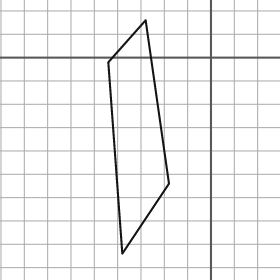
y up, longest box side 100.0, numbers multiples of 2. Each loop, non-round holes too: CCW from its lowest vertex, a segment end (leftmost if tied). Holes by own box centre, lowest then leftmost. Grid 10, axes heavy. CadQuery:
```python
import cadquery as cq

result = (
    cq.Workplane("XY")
    .moveTo(-38.0, -84.0)
    .lineTo(-18.0, -54.0)
    .lineTo(-28.0, 16.0)
    .lineTo(-44.0, -2.0)
    .close()
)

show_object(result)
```